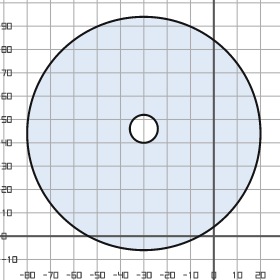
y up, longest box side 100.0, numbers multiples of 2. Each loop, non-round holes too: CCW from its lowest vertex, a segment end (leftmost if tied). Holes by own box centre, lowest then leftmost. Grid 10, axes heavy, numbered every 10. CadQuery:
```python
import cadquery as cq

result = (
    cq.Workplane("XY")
    .moveTo(-30.0, 44.0)
    .circle(50.0)
    .moveTo(-30.0, 46.0)
    .circle(6.0)
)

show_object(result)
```